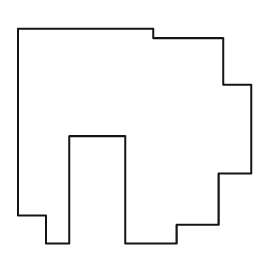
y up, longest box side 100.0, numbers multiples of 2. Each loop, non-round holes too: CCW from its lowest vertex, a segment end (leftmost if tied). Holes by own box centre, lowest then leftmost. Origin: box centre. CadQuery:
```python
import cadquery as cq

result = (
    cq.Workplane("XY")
    .moveTo(-38.0, -46.0)
    .lineTo(-28.0, -46.0)
    .lineTo(-28.0, 0.0)
    .lineTo(-4.0, 0.0)
    .lineTo(-4.0, -46.0)
    .lineTo(18.0, -46.0)
    .lineTo(18.0, -38.0)
    .lineTo(36.0, -38.0)
    .lineTo(36.0, -16.0)
    .lineTo(50.0, -16.0)
    .lineTo(50.0, 22.0)
    .lineTo(38.0, 22.0)
    .lineTo(38.0, 42.0)
    .lineTo(8.0, 42.0)
    .lineTo(8.0, 46.0)
    .lineTo(-50.0, 46.0)
    .lineTo(-50.0, -34.0)
    .lineTo(-38.0, -34.0)
    .close()
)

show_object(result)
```